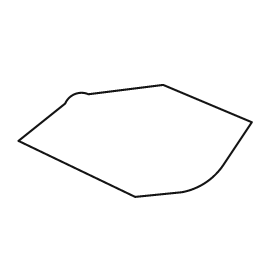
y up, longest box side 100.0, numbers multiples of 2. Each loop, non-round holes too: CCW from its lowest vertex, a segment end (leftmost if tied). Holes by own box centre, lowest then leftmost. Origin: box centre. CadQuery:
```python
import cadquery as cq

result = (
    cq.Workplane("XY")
    .moveTo(0.0, -24.0)
    .lineTo(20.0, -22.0)
    .threePointArc((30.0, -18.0), (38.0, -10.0))
    .lineTo(50.0, 8.0)
    .lineTo(12.0, 24.0)
    .lineTo(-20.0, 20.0)
    .threePointArc((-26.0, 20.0), (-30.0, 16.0))
    .lineTo(-50.0, 0.0)
    .close()
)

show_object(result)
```